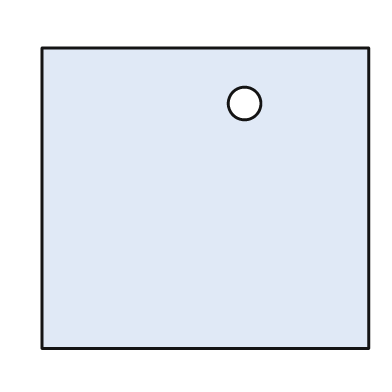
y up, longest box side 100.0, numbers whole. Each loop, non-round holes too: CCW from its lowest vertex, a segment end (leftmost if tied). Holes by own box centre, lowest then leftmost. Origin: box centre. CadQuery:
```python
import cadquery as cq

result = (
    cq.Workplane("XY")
    .moveTo(-50.0, -46.0)
    .lineTo(50.0, -46.0)
    .lineTo(50.0, 46.0)
    .lineTo(-50.0, 46.0)
    .close()
    .moveTo(12.0, 29.0)
    .circle(5.0)
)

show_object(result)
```